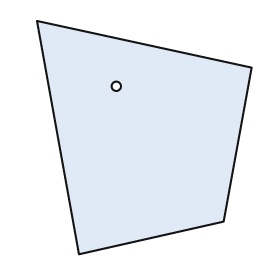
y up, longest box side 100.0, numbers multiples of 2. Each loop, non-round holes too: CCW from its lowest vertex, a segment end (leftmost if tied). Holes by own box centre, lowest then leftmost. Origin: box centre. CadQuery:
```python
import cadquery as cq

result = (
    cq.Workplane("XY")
    .moveTo(-28.0, -50.0)
    .lineTo(34.0, -36.0)
    .lineTo(46.0, 30.0)
    .lineTo(-46.0, 50.0)
    .close()
    .moveTo(-12.0, 22.0)
    .circle(2.0)
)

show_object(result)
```